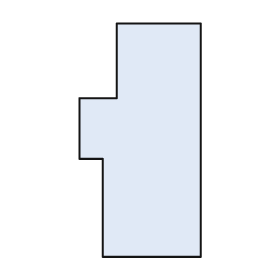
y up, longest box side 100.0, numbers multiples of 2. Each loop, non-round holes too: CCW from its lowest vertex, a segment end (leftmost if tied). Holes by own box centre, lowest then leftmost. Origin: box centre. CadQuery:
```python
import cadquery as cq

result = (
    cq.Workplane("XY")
    .moveTo(-16.0, -50.0)
    .lineTo(26.0, -50.0)
    .lineTo(26.0, 50.0)
    .lineTo(-10.0, 50.0)
    .lineTo(-10.0, 18.0)
    .lineTo(-26.0, 18.0)
    .lineTo(-26.0, -8.0)
    .lineTo(-16.0, -8.0)
    .close()
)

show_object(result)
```